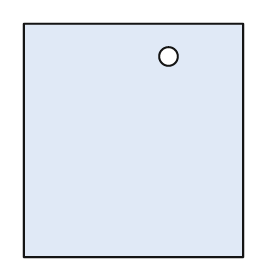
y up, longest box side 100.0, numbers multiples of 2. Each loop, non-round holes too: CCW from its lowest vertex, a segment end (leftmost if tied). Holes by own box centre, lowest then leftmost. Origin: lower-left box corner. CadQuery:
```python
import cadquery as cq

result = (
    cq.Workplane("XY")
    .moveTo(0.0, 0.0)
    .lineTo(94.0, 0.0)
    .lineTo(94.0, 100.0)
    .lineTo(0.0, 100.0)
    .close()
    .moveTo(62.0, 86.0)
    .circle(4.0)
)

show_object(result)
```